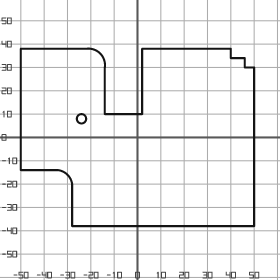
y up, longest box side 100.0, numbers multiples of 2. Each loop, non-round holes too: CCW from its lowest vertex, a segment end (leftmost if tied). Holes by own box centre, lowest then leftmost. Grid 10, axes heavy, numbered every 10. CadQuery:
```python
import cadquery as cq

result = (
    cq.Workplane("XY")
    .moveTo(-28.0, -38.0)
    .lineTo(50.0, -38.0)
    .lineTo(50.0, 30.0)
    .lineTo(46.0, 30.0)
    .lineTo(46.0, 34.0)
    .lineTo(40.0, 34.0)
    .lineTo(40.0, 38.0)
    .lineTo(2.0, 38.0)
    .lineTo(2.0, 10.0)
    .lineTo(-14.0, 10.0)
    .lineTo(-14.0, 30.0)
    .threePointArc((-16.0, 36.0), (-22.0, 38.0))
    .lineTo(-50.0, 38.0)
    .lineTo(-50.0, -14.0)
    .lineTo(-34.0, -14.0)
    .threePointArc((-30.0, -16.0), (-28.0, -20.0))
    .close()
    .moveTo(-24.0, 8.0)
    .circle(2.0)
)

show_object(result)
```